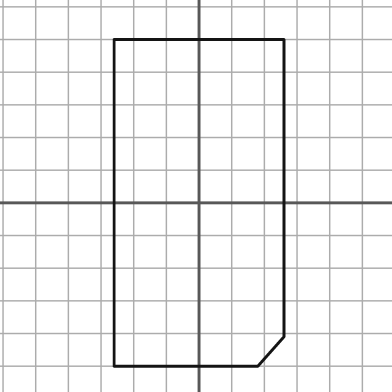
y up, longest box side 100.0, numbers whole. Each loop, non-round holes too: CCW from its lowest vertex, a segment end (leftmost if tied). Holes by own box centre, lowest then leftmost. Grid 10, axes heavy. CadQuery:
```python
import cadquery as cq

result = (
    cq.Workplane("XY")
    .moveTo(-26.0, -50.0)
    .lineTo(18.0, -50.0)
    .lineTo(26.0, -41.0)
    .lineTo(26.0, 50.0)
    .lineTo(-26.0, 50.0)
    .close()
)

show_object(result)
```